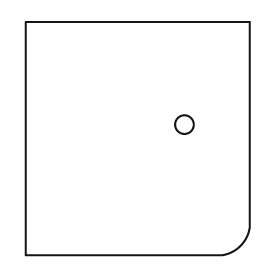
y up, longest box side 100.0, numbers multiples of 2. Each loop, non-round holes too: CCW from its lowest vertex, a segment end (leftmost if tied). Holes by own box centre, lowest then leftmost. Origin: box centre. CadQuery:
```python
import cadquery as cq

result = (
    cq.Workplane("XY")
    .moveTo(-48.0, -50.0)
    .lineTo(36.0, -50.0)
    .threePointArc((44.0, -46.0), (48.0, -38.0))
    .lineTo(48.0, 50.0)
    .lineTo(-48.0, 50.0)
    .close()
    .moveTo(20.0, 6.0)
    .circle(4.0)
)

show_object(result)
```